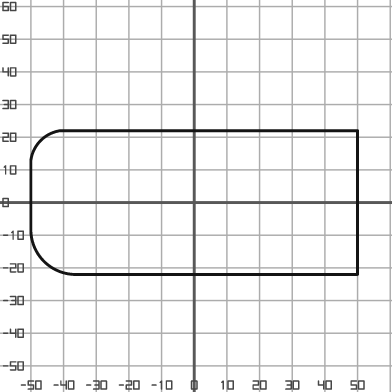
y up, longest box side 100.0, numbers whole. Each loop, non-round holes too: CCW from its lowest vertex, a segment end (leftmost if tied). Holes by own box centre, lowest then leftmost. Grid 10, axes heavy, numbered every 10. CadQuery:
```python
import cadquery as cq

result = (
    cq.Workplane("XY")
    .moveTo(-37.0, -22.0)
    .lineTo(50.0, -22.0)
    .lineTo(50.0, 22.0)
    .lineTo(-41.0, 22.0)
    .threePointArc((-47.0, 19.0), (-50.0, 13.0))
    .lineTo(-50.0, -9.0)
    .threePointArc((-46.0, -18.0), (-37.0, -22.0))
    .close()
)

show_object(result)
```